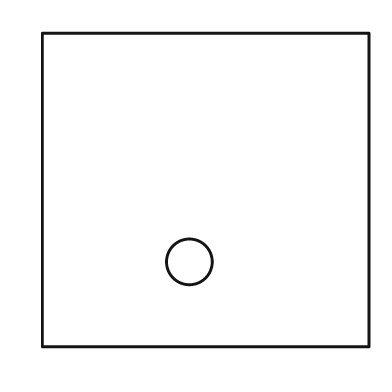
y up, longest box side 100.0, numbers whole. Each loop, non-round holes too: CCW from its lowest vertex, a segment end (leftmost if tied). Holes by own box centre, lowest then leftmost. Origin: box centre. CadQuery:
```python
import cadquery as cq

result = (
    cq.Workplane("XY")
    .moveTo(-50.0, -48.0)
    .lineTo(50.0, -48.0)
    .lineTo(50.0, 48.0)
    .lineTo(-50.0, 48.0)
    .close()
    .moveTo(-5.0, -22.0)
    .circle(7.0)
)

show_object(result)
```